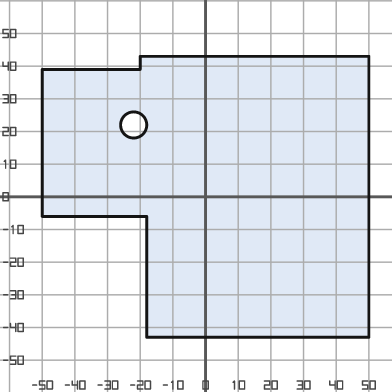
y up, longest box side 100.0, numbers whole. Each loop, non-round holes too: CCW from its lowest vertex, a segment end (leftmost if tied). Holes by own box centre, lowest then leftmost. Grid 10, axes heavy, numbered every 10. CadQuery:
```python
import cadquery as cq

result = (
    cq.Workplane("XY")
    .moveTo(-18.0, -43.0)
    .lineTo(50.0, -43.0)
    .lineTo(50.0, 43.0)
    .lineTo(-20.0, 43.0)
    .lineTo(-20.0, 39.0)
    .lineTo(-50.0, 39.0)
    .lineTo(-50.0, -6.0)
    .lineTo(-18.0, -6.0)
    .close()
    .moveTo(-22.0, 22.0)
    .circle(4.0)
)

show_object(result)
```